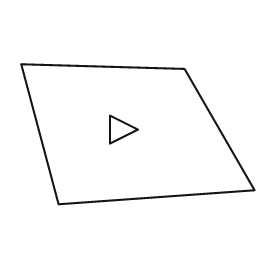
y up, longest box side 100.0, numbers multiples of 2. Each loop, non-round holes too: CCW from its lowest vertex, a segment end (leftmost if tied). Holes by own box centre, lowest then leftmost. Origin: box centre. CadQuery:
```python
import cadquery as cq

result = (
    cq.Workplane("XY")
    .moveTo(-34.0, -30.0)
    .lineTo(50.0, -24.0)
    .lineTo(20.0, 28.0)
    .lineTo(-50.0, 30.0)
    .close()
    .moveTo(-12.0, -4.0)
    .lineTo(0.0, 2.0)
    .lineTo(-12.0, 8.0)
    .close()
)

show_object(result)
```